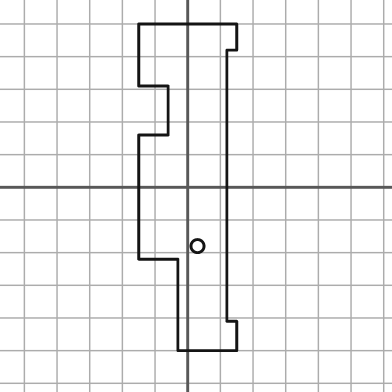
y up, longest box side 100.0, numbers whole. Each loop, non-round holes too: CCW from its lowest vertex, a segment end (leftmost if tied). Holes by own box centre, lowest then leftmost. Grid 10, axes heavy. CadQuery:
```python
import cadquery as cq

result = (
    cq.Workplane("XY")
    .moveTo(-3.0, -50.0)
    .lineTo(15.0, -50.0)
    .lineTo(15.0, -41.0)
    .lineTo(12.0, -41.0)
    .lineTo(12.0, 42.0)
    .lineTo(15.0, 42.0)
    .lineTo(15.0, 50.0)
    .lineTo(-15.0, 50.0)
    .lineTo(-15.0, 31.0)
    .lineTo(-6.0, 31.0)
    .lineTo(-6.0, 16.0)
    .lineTo(-15.0, 16.0)
    .lineTo(-15.0, -22.0)
    .lineTo(-3.0, -22.0)
    .close()
    .moveTo(3.0, -18.0)
    .circle(2.0)
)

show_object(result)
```